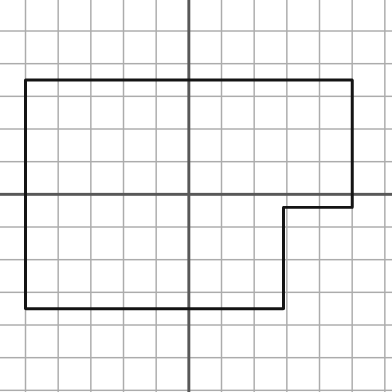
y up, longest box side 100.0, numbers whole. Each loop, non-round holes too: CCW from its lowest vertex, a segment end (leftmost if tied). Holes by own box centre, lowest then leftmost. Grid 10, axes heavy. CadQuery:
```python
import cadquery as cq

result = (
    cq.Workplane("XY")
    .moveTo(-50.0, -35.0)
    .lineTo(29.0, -35.0)
    .lineTo(29.0, -4.0)
    .lineTo(50.0, -4.0)
    .lineTo(50.0, 35.0)
    .lineTo(-50.0, 35.0)
    .close()
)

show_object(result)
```